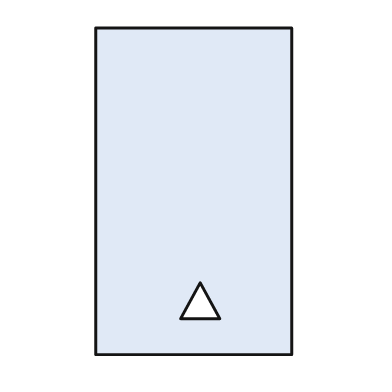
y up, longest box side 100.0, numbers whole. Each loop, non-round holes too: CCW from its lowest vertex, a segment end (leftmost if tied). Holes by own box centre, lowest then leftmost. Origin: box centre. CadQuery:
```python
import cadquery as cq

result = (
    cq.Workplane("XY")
    .moveTo(-30.0, -50.0)
    .lineTo(30.0, -50.0)
    .lineTo(30.0, 50.0)
    .lineTo(-30.0, 50.0)
    .close()
    .moveTo(-4.0, -39.0)
    .lineTo(8.0, -39.0)
    .lineTo(2.0, -28.0)
    .close()
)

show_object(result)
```